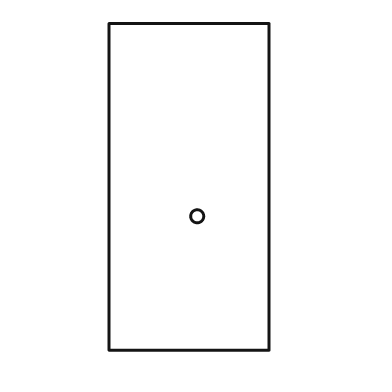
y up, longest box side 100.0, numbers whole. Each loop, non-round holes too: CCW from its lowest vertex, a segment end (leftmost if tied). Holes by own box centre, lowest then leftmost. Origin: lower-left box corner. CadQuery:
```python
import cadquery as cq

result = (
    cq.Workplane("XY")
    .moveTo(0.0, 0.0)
    .lineTo(49.0, 0.0)
    .lineTo(49.0, 100.0)
    .lineTo(0.0, 100.0)
    .close()
    .moveTo(27.0, 41.0)
    .circle(2.0)
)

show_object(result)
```